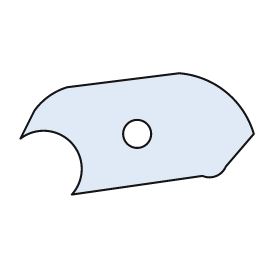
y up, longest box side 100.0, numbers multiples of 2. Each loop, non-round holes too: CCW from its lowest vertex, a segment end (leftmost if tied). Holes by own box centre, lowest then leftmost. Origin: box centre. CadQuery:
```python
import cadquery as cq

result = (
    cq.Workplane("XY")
    .moveTo(-28.0, -26.0)
    .lineTo(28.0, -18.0)
    .threePointArc((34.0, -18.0), (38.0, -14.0))
    .lineTo(50.0, 0.0)
    .threePointArc((38.0, 18.0), (18.0, 26.0))
    .lineTo(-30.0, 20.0)
    .threePointArc((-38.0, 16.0), (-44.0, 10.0))
    .lineTo(-50.0, -2.0)
    .threePointArc((-28.0, -4.0), (-28.0, -26.0))
    .close()
    .moveTo(0.0, 0.0)
    .circle(6.0)
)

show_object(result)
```